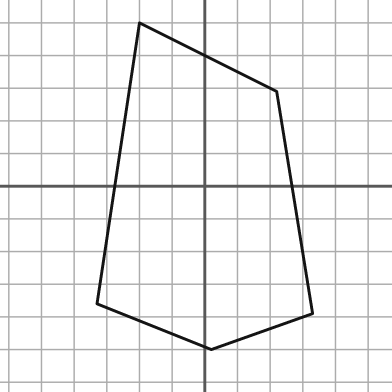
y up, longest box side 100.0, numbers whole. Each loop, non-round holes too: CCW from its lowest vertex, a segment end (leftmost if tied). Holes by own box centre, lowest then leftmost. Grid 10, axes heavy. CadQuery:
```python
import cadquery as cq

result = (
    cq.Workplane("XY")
    .moveTo(2.0, -50.0)
    .lineTo(33.0, -39.0)
    .lineTo(22.0, 29.0)
    .lineTo(-20.0, 50.0)
    .lineTo(-33.0, -36.0)
    .close()
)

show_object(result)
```